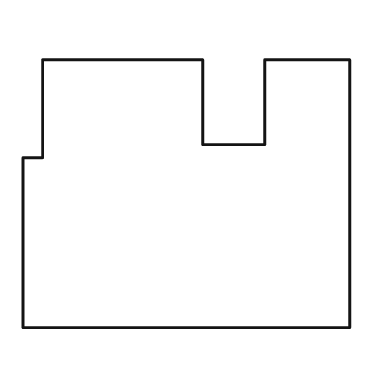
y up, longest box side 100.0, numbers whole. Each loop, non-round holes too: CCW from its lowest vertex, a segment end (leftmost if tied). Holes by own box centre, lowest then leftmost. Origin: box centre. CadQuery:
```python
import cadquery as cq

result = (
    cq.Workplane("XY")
    .moveTo(-50.0, -41.0)
    .lineTo(50.0, -41.0)
    .lineTo(50.0, 41.0)
    .lineTo(24.0, 41.0)
    .lineTo(24.0, 15.0)
    .lineTo(5.0, 15.0)
    .lineTo(5.0, 41.0)
    .lineTo(-44.0, 41.0)
    .lineTo(-44.0, 11.0)
    .lineTo(-50.0, 11.0)
    .close()
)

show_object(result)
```